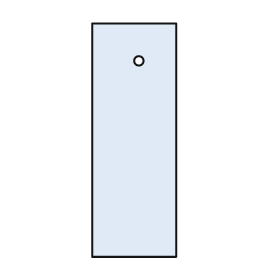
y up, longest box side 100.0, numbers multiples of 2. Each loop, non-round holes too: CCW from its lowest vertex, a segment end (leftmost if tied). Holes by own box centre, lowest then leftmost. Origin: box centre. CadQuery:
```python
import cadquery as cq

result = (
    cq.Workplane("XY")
    .moveTo(-18.0, -50.0)
    .lineTo(18.0, -50.0)
    .lineTo(18.0, 50.0)
    .lineTo(-18.0, 50.0)
    .close()
    .moveTo(2.0, 34.0)
    .circle(2.0)
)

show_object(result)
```